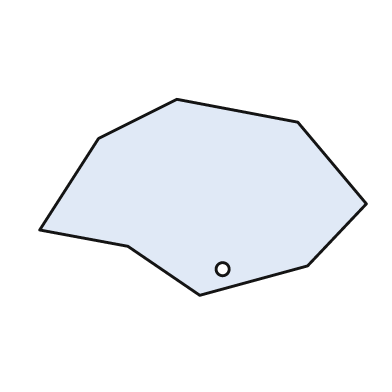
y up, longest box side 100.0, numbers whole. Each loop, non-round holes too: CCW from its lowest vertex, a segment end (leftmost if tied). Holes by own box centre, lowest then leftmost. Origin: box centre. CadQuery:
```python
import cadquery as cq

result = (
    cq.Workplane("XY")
    .moveTo(-1.0, -30.0)
    .lineTo(32.0, -21.0)
    .lineTo(50.0, -2.0)
    .lineTo(29.0, 23.0)
    .lineTo(-8.0, 30.0)
    .lineTo(-32.0, 18.0)
    .lineTo(-50.0, -10.0)
    .lineTo(-23.0, -15.0)
    .close()
    .moveTo(6.0, -22.0)
    .circle(2.0)
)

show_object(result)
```